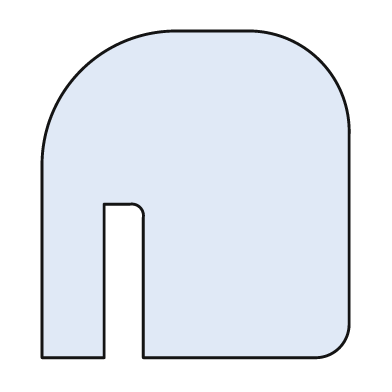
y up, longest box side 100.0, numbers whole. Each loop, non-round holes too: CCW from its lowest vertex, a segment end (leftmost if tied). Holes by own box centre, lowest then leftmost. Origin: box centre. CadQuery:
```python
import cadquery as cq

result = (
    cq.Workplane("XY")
    .moveTo(-47.0, -50.0)
    .lineTo(-28.0, -50.0)
    .lineTo(-28.0, -3.0)
    .lineTo(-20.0, -3.0)
    .threePointArc((-17.0, -4.0), (-16.0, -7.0))
    .lineTo(-16.0, -50.0)
    .lineTo(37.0, -50.0)
    .threePointArc((44.0, -47.0), (47.0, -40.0))
    .lineTo(47.0, 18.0)
    .threePointArc((38.0, 41.0), (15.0, 50.0))
    .lineTo(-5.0, 50.0)
    .threePointArc((-35.0, 38.0), (-47.0, 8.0))
    .close()
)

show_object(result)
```